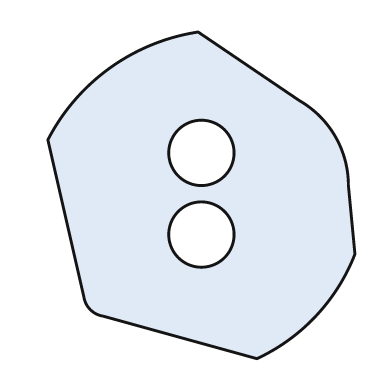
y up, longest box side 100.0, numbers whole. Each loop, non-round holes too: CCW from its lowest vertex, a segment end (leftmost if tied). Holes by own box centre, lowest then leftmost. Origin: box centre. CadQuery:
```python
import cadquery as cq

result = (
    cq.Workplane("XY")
    .moveTo(17.0, -50.0)
    .threePointArc((35.0, -37.0), (47.0, -18.0))
    .lineTo(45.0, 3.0)
    .threePointArc((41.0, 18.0), (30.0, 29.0))
    .lineTo(-1.0, 50.0)
    .threePointArc((-28.0, 39.0), (-47.0, 17.0))
    .lineTo(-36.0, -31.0)
    .threePointArc((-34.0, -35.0), (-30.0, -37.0))
    .close()
    .moveTo(0.0, -12.0)
    .circle(10.0)
    .moveTo(0.0, 13.0)
    .circle(10.0)
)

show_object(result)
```